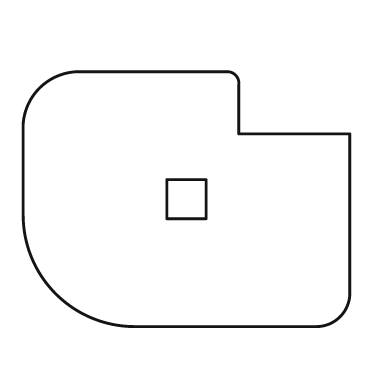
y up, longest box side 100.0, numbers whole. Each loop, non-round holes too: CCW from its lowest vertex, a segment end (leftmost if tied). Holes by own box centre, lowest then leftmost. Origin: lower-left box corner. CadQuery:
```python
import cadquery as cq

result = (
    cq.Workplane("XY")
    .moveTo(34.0, 0.0)
    .lineTo(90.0, 0.0)
    .threePointArc((97.0, 3.0), (100.0, 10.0))
    .lineTo(100.0, 59.0)
    .lineTo(66.0, 59.0)
    .lineTo(66.0, 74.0)
    .threePointArc((65.0, 77.0), (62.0, 78.0))
    .lineTo(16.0, 78.0)
    .threePointArc((5.0, 73.0), (0.0, 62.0))
    .lineTo(0.0, 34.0)
    .threePointArc((10.0, 10.0), (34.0, 0.0))
    .close()
    .moveTo(44.0, 33.0)
    .lineTo(56.0, 33.0)
    .lineTo(56.0, 45.0)
    .lineTo(44.0, 45.0)
    .close()
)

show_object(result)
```